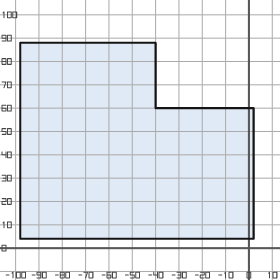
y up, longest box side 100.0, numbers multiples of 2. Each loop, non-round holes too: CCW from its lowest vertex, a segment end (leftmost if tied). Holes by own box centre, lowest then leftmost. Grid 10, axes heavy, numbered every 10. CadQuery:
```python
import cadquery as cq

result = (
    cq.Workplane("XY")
    .moveTo(-98.0, 4.0)
    .lineTo(2.0, 4.0)
    .lineTo(2.0, 60.0)
    .lineTo(-40.0, 60.0)
    .lineTo(-40.0, 88.0)
    .lineTo(-98.0, 88.0)
    .close()
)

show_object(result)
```